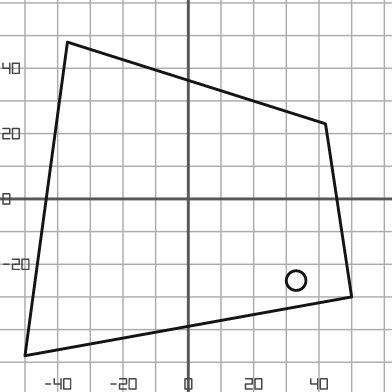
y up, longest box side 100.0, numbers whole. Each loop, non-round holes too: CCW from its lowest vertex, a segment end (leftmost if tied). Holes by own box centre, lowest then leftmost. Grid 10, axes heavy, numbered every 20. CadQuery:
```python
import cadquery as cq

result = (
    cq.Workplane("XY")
    .moveTo(-50.0, -48.0)
    .lineTo(50.0, -30.0)
    .lineTo(42.0, 23.0)
    .lineTo(-37.0, 48.0)
    .close()
    .moveTo(33.0, -25.0)
    .circle(3.0)
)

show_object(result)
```